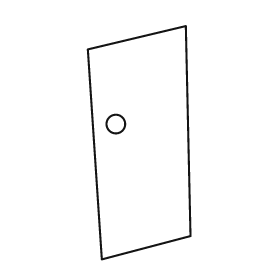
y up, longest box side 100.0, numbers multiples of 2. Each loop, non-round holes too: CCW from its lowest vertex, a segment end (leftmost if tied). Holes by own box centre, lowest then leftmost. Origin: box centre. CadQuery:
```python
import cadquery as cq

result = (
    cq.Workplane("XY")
    .moveTo(-16.0, -50.0)
    .lineTo(22.0, -40.0)
    .lineTo(20.0, 50.0)
    .lineTo(-22.0, 40.0)
    .close()
    .moveTo(-10.0, 8.0)
    .circle(4.0)
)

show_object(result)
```